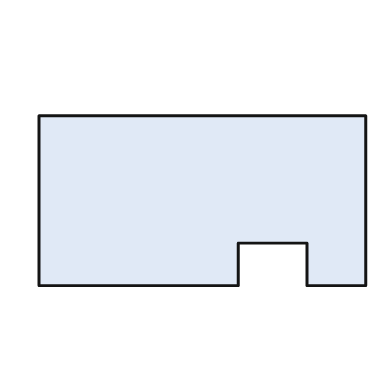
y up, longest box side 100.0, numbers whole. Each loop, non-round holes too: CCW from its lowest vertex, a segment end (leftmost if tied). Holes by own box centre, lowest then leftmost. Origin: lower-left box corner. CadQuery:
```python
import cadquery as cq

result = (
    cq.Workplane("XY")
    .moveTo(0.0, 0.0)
    .lineTo(61.0, 0.0)
    .lineTo(61.0, 13.0)
    .lineTo(82.0, 13.0)
    .lineTo(82.0, 0.0)
    .lineTo(100.0, 0.0)
    .lineTo(100.0, 52.0)
    .lineTo(0.0, 52.0)
    .close()
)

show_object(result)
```